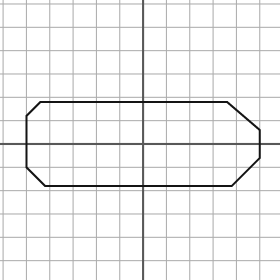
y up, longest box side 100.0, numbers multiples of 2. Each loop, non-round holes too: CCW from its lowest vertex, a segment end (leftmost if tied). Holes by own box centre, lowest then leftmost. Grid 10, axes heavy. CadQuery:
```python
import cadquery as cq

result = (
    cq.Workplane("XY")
    .moveTo(-42.0, -18.0)
    .lineTo(38.0, -18.0)
    .lineTo(50.0, -6.0)
    .lineTo(50.0, 6.0)
    .lineTo(36.0, 18.0)
    .lineTo(-44.0, 18.0)
    .lineTo(-50.0, 12.0)
    .lineTo(-50.0, -10.0)
    .close()
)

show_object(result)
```